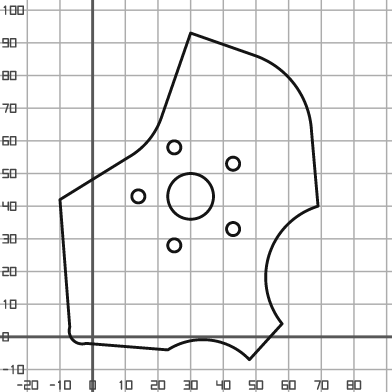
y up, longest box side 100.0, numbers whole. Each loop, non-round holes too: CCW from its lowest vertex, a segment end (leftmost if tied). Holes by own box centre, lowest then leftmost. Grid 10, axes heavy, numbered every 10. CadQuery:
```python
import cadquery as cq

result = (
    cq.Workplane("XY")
    .moveTo(48.0, -7.0)
    .lineTo(58.0, 4.0)
    .threePointArc((54.0, 25.0), (69.0, 40.0))
    .lineTo(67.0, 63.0)
    .threePointArc((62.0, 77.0), (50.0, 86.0))
    .lineTo(30.0, 93.0)
    .lineTo(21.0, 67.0)
    .threePointArc((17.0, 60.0), (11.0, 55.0))
    .lineTo(-10.0, 42.0)
    .lineTo(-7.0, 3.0)
    .threePointArc((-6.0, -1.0), (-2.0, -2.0))
    .lineTo(23.0, -4.0)
    .threePointArc((36.0, -1.0), (48.0, -7.0))
    .close()
    .moveTo(25.0, 28.0)
    .circle(2.0)
    .moveTo(43.0, 33.0)
    .circle(2.0)
    .moveTo(14.0, 43.0)
    .circle(2.0)
    .moveTo(30.0, 43.0)
    .circle(7.0)
    .moveTo(43.0, 53.0)
    .circle(2.0)
    .moveTo(25.0, 58.0)
    .circle(2.0)
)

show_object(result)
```